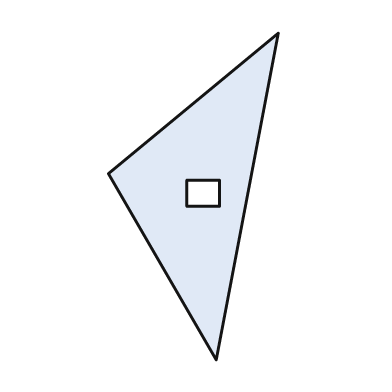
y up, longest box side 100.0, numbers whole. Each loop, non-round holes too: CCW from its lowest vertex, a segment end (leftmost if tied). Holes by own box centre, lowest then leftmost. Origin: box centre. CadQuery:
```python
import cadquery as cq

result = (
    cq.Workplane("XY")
    .moveTo(7.0, -50.0)
    .lineTo(26.0, 50.0)
    .lineTo(-26.0, 7.0)
    .close()
    .moveTo(-2.0, -3.0)
    .lineTo(8.0, -3.0)
    .lineTo(8.0, 5.0)
    .lineTo(-2.0, 5.0)
    .close()
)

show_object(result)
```